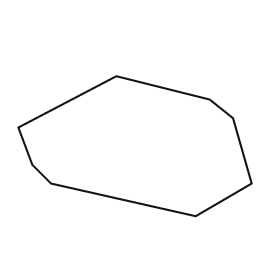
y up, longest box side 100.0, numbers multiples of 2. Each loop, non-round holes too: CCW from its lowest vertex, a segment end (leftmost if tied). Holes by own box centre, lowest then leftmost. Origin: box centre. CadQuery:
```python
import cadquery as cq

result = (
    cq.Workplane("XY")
    .moveTo(26.0, -30.0)
    .lineTo(50.0, -16.0)
    .lineTo(42.0, 12.0)
    .lineTo(32.0, 20.0)
    .lineTo(-8.0, 30.0)
    .lineTo(-50.0, 8.0)
    .lineTo(-44.0, -8.0)
    .lineTo(-36.0, -16.0)
    .close()
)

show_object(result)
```